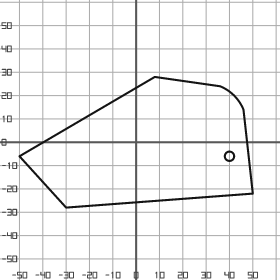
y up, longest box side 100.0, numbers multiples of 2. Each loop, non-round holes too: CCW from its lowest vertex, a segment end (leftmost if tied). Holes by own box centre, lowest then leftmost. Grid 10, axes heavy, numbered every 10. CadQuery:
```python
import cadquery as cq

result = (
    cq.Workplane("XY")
    .moveTo(-30.0, -28.0)
    .lineTo(50.0, -22.0)
    .lineTo(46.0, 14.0)
    .threePointArc((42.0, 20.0), (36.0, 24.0))
    .lineTo(8.0, 28.0)
    .lineTo(-50.0, -6.0)
    .close()
    .moveTo(40.0, -6.0)
    .circle(2.0)
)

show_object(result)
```